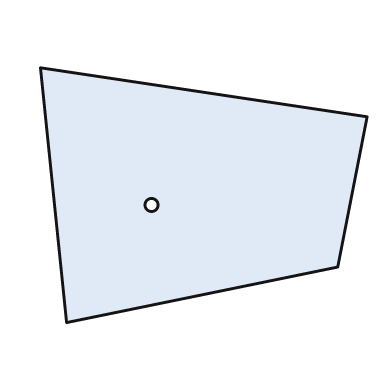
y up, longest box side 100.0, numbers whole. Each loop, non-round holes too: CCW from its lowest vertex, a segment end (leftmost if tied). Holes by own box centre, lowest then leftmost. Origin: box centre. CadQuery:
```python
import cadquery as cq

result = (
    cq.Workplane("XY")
    .moveTo(-42.0, -39.0)
    .lineTo(41.0, -22.0)
    .lineTo(50.0, 24.0)
    .lineTo(-50.0, 39.0)
    .close()
    .moveTo(-16.0, -3.0)
    .circle(2.0)
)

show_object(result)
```